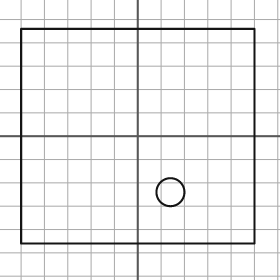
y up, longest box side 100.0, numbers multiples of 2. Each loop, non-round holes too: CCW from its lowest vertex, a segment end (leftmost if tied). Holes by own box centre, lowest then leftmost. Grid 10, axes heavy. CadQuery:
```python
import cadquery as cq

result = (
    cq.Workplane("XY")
    .moveTo(-50.0, -46.0)
    .lineTo(50.0, -46.0)
    .lineTo(50.0, 46.0)
    .lineTo(-50.0, 46.0)
    .close()
    .moveTo(14.0, -24.0)
    .circle(6.0)
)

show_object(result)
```